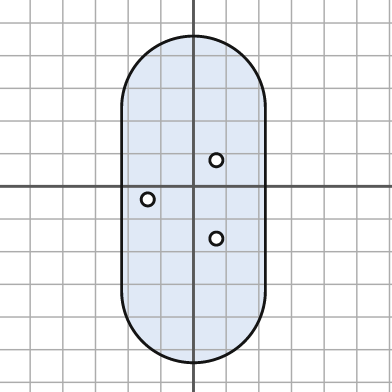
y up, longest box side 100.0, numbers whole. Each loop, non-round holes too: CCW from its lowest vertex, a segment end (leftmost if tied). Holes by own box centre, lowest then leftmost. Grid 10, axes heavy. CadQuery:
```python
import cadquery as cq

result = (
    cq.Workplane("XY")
    .moveTo(-22.0, -32.0)
    .threePointArc((0.0, -54.0), (22.0, -32.0))
    .lineTo(22.0, 24.0)
    .threePointArc((0.0, 46.0), (-22.0, 24.0))
    .close()
    .moveTo(7.0, -16.0)
    .circle(2.0)
    .moveTo(-14.0, -4.0)
    .circle(2.0)
    .moveTo(7.0, 8.0)
    .circle(2.0)
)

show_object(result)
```